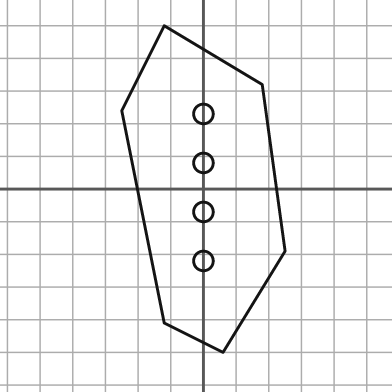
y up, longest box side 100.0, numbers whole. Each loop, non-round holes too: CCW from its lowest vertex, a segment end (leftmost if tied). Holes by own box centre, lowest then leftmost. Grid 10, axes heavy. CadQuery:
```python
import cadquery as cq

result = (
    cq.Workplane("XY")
    .moveTo(6.0, -50.0)
    .lineTo(25.0, -19.0)
    .lineTo(18.0, 32.0)
    .lineTo(-12.0, 50.0)
    .lineTo(-25.0, 24.0)
    .lineTo(-12.0, -41.0)
    .close()
    .moveTo(0.0, -22.0)
    .circle(3.0)
    .moveTo(0.0, -7.0)
    .circle(3.0)
    .moveTo(0.0, 8.0)
    .circle(3.0)
    .moveTo(0.0, 23.0)
    .circle(3.0)
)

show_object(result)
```